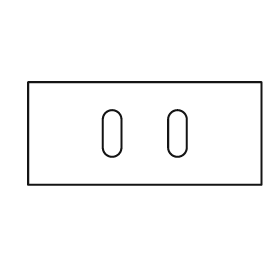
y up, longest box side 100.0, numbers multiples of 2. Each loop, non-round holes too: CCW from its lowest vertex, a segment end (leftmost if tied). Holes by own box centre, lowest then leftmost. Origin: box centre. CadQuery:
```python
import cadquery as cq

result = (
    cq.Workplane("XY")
    .moveTo(-50.0, -22.0)
    .lineTo(50.0, -22.0)
    .lineTo(50.0, 22.0)
    .lineTo(-50.0, 22.0)
    .close()
    .moveTo(-18.0, -6.0)
    .threePointArc((-14.0, -10.0), (-10.0, -6.0))
    .lineTo(-10.0, 6.0)
    .threePointArc((-14.0, 10.0), (-18.0, 6.0))
    .close()
    .moveTo(10.0, -6.0)
    .threePointArc((14.0, -10.0), (18.0, -6.0))
    .lineTo(18.0, 6.0)
    .threePointArc((14.0, 10.0), (10.0, 6.0))
    .close()
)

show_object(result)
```